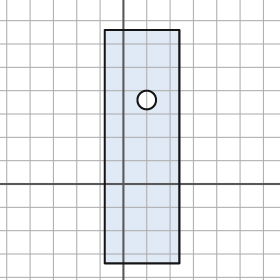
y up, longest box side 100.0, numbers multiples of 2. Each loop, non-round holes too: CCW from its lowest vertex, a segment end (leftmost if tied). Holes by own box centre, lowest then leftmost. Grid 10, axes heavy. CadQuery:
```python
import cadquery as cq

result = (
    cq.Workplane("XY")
    .moveTo(-8.0, -34.0)
    .lineTo(24.0, -34.0)
    .lineTo(24.0, 66.0)
    .lineTo(-8.0, 66.0)
    .close()
    .moveTo(10.0, 36.0)
    .circle(4.0)
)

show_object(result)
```